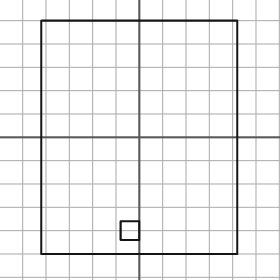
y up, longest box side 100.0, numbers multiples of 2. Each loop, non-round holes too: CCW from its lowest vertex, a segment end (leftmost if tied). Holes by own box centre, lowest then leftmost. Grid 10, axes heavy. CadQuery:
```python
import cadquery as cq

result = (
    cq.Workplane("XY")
    .moveTo(-42.0, -50.0)
    .lineTo(42.0, -50.0)
    .lineTo(42.0, 50.0)
    .lineTo(-42.0, 50.0)
    .close()
    .moveTo(-8.0, -44.0)
    .lineTo(0.0, -44.0)
    .lineTo(0.0, -36.0)
    .lineTo(-8.0, -36.0)
    .close()
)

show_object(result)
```